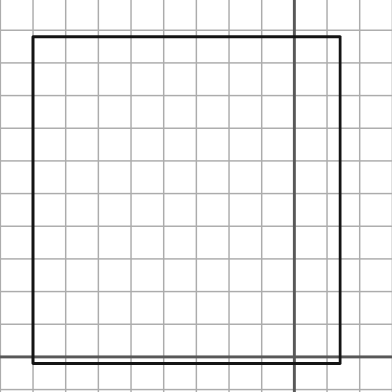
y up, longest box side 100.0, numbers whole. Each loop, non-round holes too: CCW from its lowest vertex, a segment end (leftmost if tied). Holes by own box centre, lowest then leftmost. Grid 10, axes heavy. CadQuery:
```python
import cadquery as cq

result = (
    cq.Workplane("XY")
    .moveTo(-80.0, -2.0)
    .lineTo(14.0, -2.0)
    .lineTo(14.0, 98.0)
    .lineTo(-80.0, 98.0)
    .close()
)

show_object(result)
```